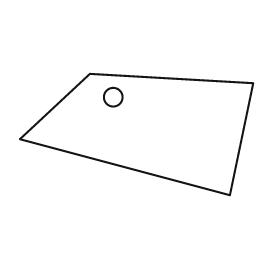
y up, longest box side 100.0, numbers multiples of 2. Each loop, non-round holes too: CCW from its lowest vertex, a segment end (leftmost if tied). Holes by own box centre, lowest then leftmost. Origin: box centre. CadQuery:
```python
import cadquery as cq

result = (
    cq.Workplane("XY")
    .moveTo(40.0, -26.0)
    .lineTo(50.0, 22.0)
    .lineTo(-20.0, 26.0)
    .lineTo(-50.0, -2.0)
    .close()
    .moveTo(-10.0, 16.0)
    .circle(4.0)
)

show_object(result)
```